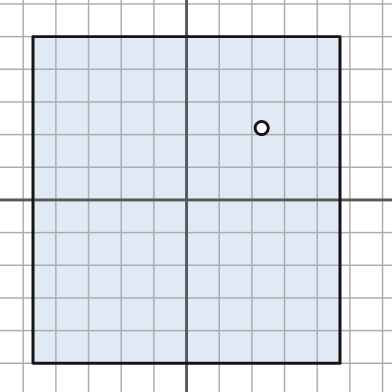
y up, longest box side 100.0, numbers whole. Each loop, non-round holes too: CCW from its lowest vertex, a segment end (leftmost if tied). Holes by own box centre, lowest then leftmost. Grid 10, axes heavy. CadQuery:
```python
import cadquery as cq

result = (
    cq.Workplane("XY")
    .moveTo(-47.0, -50.0)
    .lineTo(47.0, -50.0)
    .lineTo(47.0, 50.0)
    .lineTo(-47.0, 50.0)
    .close()
    .moveTo(23.0, 22.0)
    .circle(2.0)
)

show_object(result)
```